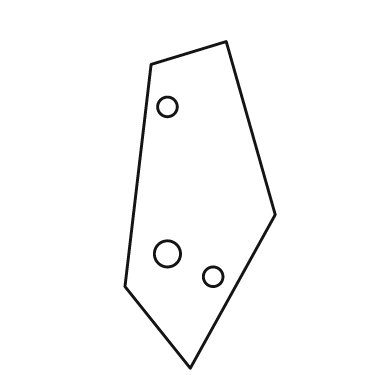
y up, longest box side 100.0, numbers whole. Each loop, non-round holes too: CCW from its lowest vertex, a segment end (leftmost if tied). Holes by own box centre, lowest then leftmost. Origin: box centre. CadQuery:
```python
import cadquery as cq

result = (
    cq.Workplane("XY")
    .moveTo(-3.0, -50.0)
    .lineTo(23.0, -3.0)
    .lineTo(8.0, 50.0)
    .lineTo(-15.0, 43.0)
    .lineTo(-23.0, -25.0)
    .close()
    .moveTo(4.0, -22.0)
    .circle(3.0)
    .moveTo(-10.0, -15.0)
    .circle(4.0)
    .moveTo(-10.0, 30.0)
    .circle(3.0)
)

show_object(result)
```